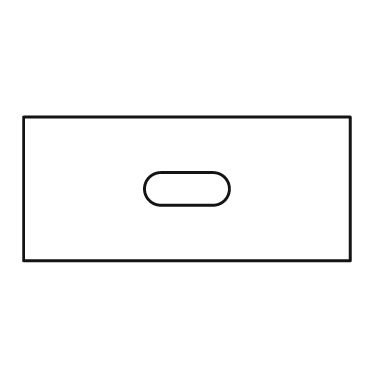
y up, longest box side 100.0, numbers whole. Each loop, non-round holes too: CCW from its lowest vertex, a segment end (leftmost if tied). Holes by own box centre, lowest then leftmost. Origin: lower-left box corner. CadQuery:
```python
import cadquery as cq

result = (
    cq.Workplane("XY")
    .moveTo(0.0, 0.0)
    .lineTo(100.0, 0.0)
    .lineTo(100.0, 44.0)
    .lineTo(0.0, 44.0)
    .close()
    .moveTo(42.0, 17.0)
    .lineTo(58.0, 17.0)
    .threePointArc((63.0, 22.0), (58.0, 27.0))
    .lineTo(42.0, 27.0)
    .threePointArc((37.0, 22.0), (42.0, 17.0))
    .close()
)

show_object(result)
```